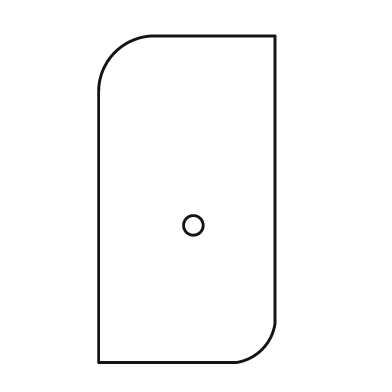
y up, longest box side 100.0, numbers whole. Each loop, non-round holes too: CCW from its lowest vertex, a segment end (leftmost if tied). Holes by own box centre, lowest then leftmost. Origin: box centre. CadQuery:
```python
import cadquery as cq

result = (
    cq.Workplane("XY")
    .moveTo(-27.0, -50.0)
    .lineTo(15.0, -50.0)
    .threePointArc((23.0, -46.0), (27.0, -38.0))
    .lineTo(27.0, 50.0)
    .lineTo(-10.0, 50.0)
    .threePointArc((-22.0, 45.0), (-27.0, 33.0))
    .close()
    .moveTo(2.0, -8.0)
    .circle(3.0)
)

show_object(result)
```